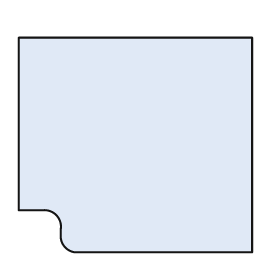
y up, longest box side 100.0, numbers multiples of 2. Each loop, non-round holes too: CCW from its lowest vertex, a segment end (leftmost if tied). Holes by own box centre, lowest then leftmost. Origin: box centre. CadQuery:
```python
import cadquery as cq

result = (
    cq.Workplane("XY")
    .moveTo(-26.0, -46.0)
    .lineTo(50.0, -46.0)
    .lineTo(50.0, 46.0)
    .lineTo(-50.0, 46.0)
    .lineTo(-50.0, -28.0)
    .lineTo(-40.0, -28.0)
    .threePointArc((-34.0, -30.0), (-32.0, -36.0))
    .lineTo(-32.0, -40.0)
    .threePointArc((-30.0, -44.0), (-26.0, -46.0))
    .close()
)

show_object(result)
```